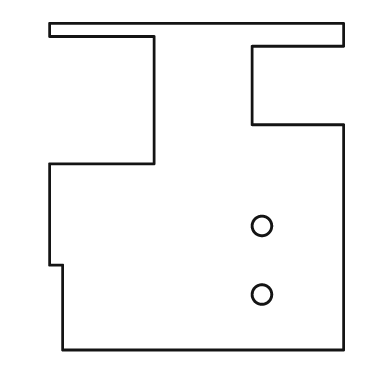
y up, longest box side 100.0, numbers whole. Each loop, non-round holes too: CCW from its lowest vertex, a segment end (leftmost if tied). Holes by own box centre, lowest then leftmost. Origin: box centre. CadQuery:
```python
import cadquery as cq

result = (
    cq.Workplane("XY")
    .moveTo(-41.0, -50.0)
    .lineTo(45.0, -50.0)
    .lineTo(45.0, 19.0)
    .lineTo(17.0, 19.0)
    .lineTo(17.0, 43.0)
    .lineTo(45.0, 43.0)
    .lineTo(45.0, 50.0)
    .lineTo(-45.0, 50.0)
    .lineTo(-45.0, 46.0)
    .lineTo(-13.0, 46.0)
    .lineTo(-13.0, 7.0)
    .lineTo(-45.0, 7.0)
    .lineTo(-45.0, -24.0)
    .lineTo(-41.0, -24.0)
    .close()
    .moveTo(20.0, -33.0)
    .circle(3.0)
    .moveTo(20.0, -12.0)
    .circle(3.0)
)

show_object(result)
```